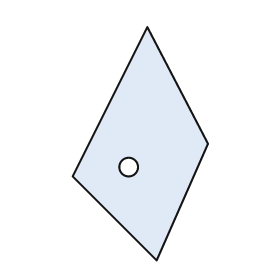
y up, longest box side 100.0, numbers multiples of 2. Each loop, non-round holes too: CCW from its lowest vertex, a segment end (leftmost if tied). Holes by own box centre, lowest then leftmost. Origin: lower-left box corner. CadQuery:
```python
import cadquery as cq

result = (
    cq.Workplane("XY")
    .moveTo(36.0, 0.0)
    .lineTo(58.0, 50.0)
    .lineTo(32.0, 100.0)
    .lineTo(0.0, 36.0)
    .close()
    .moveTo(24.0, 40.0)
    .circle(4.0)
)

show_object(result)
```